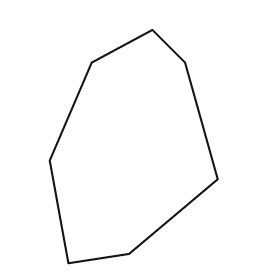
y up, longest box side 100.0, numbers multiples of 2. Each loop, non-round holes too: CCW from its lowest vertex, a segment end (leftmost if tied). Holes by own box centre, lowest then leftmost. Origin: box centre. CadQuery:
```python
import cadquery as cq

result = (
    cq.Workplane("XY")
    .moveTo(-28.0, -50.0)
    .lineTo(-2.0, -46.0)
    .lineTo(36.0, -14.0)
    .lineTo(22.0, 36.0)
    .lineTo(8.0, 50.0)
    .lineTo(-18.0, 36.0)
    .lineTo(-36.0, -6.0)
    .close()
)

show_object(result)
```